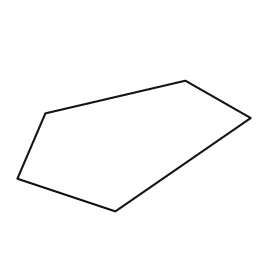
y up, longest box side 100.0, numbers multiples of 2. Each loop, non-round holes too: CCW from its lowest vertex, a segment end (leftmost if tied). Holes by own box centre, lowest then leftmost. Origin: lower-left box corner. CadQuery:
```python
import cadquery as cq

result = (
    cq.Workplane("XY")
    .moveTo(42.0, 0.0)
    .lineTo(100.0, 40.0)
    .lineTo(72.0, 56.0)
    .lineTo(12.0, 42.0)
    .lineTo(0.0, 14.0)
    .close()
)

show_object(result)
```